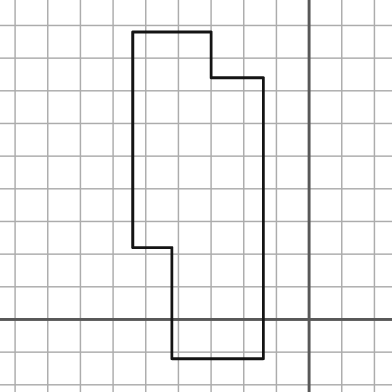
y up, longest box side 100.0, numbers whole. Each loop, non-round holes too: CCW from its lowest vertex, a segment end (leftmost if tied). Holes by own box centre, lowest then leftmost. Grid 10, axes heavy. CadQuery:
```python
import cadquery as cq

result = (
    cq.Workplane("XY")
    .moveTo(-42.0, -12.0)
    .lineTo(-14.0, -12.0)
    .lineTo(-14.0, 74.0)
    .lineTo(-30.0, 74.0)
    .lineTo(-30.0, 88.0)
    .lineTo(-54.0, 88.0)
    .lineTo(-54.0, 22.0)
    .lineTo(-42.0, 22.0)
    .close()
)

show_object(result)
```